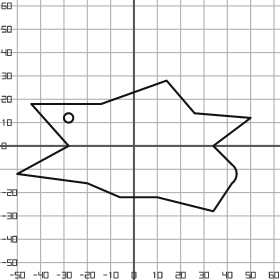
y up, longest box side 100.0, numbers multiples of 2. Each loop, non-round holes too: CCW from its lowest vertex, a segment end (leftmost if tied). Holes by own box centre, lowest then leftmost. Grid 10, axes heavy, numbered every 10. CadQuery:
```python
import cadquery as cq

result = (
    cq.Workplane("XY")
    .moveTo(34.0, -28.0)
    .lineTo(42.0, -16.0)
    .threePointArc((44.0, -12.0), (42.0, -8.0))
    .lineTo(34.0, 0.0)
    .lineTo(50.0, 12.0)
    .lineTo(26.0, 14.0)
    .lineTo(14.0, 28.0)
    .lineTo(-14.0, 18.0)
    .lineTo(-44.0, 18.0)
    .lineTo(-28.0, 0.0)
    .lineTo(-50.0, -12.0)
    .lineTo(-20.0, -16.0)
    .lineTo(-6.0, -22.0)
    .lineTo(10.0, -22.0)
    .close()
    .moveTo(-28.0, 12.0)
    .circle(2.0)
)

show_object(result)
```